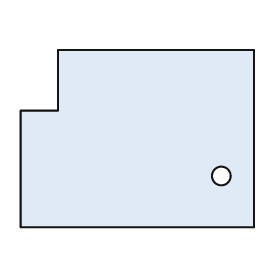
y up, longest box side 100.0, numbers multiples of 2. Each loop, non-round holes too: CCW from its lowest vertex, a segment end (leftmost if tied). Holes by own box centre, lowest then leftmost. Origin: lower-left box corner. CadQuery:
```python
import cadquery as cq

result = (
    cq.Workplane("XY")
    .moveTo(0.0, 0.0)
    .lineTo(100.0, 0.0)
    .lineTo(100.0, 76.0)
    .lineTo(16.0, 76.0)
    .lineTo(16.0, 50.0)
    .lineTo(0.0, 50.0)
    .close()
    .moveTo(86.0, 22.0)
    .circle(4.0)
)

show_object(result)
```